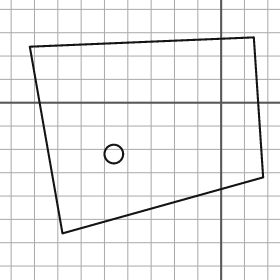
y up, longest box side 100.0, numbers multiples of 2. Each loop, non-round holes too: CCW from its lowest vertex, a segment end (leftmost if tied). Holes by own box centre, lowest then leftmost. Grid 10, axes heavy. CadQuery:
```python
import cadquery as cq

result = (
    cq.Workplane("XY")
    .moveTo(-68.0, -56.0)
    .lineTo(18.0, -32.0)
    .lineTo(14.0, 28.0)
    .lineTo(-82.0, 24.0)
    .close()
    .moveTo(-46.0, -22.0)
    .circle(4.0)
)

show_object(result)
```